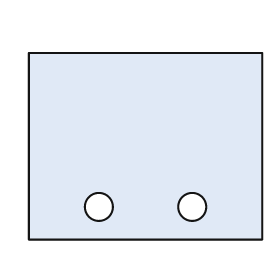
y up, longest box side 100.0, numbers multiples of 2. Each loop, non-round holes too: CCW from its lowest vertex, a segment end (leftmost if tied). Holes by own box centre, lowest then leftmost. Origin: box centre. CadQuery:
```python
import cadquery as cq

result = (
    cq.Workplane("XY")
    .moveTo(-50.0, -40.0)
    .lineTo(50.0, -40.0)
    .lineTo(50.0, 40.0)
    .lineTo(-50.0, 40.0)
    .close()
    .moveTo(-20.0, -26.0)
    .circle(6.0)
    .moveTo(20.0, -26.0)
    .circle(6.0)
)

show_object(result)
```